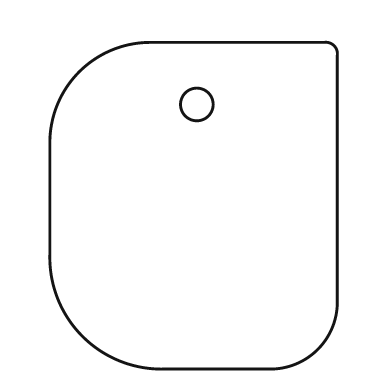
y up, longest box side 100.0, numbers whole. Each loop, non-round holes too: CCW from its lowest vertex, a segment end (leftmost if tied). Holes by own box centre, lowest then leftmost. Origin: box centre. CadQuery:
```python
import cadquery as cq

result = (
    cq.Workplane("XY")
    .moveTo(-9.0, -50.0)
    .lineTo(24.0, -50.0)
    .threePointArc((38.0, -44.0), (44.0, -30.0))
    .lineTo(44.0, 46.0)
    .threePointArc((43.0, 49.0), (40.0, 50.0))
    .lineTo(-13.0, 50.0)
    .threePointArc((-35.0, 41.0), (-44.0, 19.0))
    .lineTo(-44.0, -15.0)
    .threePointArc((-34.0, -40.0), (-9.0, -50.0))
    .close()
    .moveTo(1.0, 31.0)
    .circle(5.0)
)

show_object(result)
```